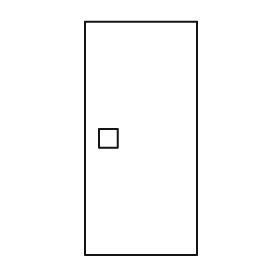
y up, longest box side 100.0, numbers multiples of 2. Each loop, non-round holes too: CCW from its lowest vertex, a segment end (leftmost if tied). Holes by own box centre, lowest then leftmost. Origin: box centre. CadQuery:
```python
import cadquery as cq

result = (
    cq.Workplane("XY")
    .moveTo(-24.0, -50.0)
    .lineTo(24.0, -50.0)
    .lineTo(24.0, 50.0)
    .lineTo(-24.0, 50.0)
    .close()
    .moveTo(-18.0, -4.0)
    .lineTo(-10.0, -4.0)
    .lineTo(-10.0, 4.0)
    .lineTo(-18.0, 4.0)
    .close()
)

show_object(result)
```